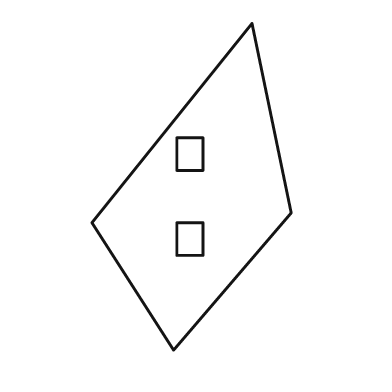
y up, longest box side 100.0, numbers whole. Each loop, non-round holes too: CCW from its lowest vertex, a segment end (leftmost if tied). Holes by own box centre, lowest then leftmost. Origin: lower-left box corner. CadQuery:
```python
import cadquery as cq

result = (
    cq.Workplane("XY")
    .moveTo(25.0, 0.0)
    .lineTo(61.0, 42.0)
    .lineTo(49.0, 100.0)
    .lineTo(0.0, 39.0)
    .close()
    .moveTo(26.0, 29.0)
    .lineTo(34.0, 29.0)
    .lineTo(34.0, 39.0)
    .lineTo(26.0, 39.0)
    .close()
    .moveTo(26.0, 55.0)
    .lineTo(34.0, 55.0)
    .lineTo(34.0, 65.0)
    .lineTo(26.0, 65.0)
    .close()
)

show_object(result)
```